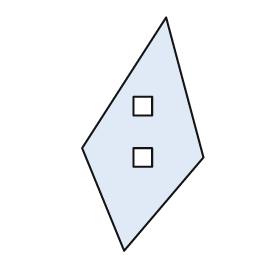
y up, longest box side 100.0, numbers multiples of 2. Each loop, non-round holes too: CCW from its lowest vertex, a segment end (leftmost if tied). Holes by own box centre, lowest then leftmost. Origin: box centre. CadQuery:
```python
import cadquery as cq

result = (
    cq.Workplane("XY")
    .moveTo(-8.0, -50.0)
    .lineTo(26.0, -10.0)
    .lineTo(10.0, 50.0)
    .lineTo(-26.0, -6.0)
    .close()
    .moveTo(-4.0, -14.0)
    .lineTo(4.0, -14.0)
    .lineTo(4.0, -6.0)
    .lineTo(-4.0, -6.0)
    .close()
    .moveTo(-4.0, 8.0)
    .lineTo(4.0, 8.0)
    .lineTo(4.0, 16.0)
    .lineTo(-4.0, 16.0)
    .close()
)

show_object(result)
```